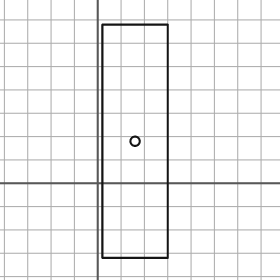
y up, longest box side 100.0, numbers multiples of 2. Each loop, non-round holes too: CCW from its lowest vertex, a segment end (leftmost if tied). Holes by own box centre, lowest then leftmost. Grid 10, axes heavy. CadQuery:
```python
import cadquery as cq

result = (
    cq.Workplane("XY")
    .moveTo(2.0, -32.0)
    .lineTo(30.0, -32.0)
    .lineTo(30.0, 68.0)
    .lineTo(2.0, 68.0)
    .close()
    .moveTo(16.0, 18.0)
    .circle(2.0)
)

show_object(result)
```